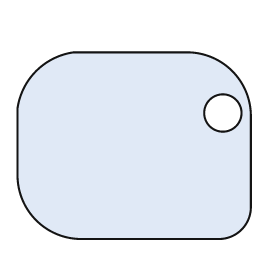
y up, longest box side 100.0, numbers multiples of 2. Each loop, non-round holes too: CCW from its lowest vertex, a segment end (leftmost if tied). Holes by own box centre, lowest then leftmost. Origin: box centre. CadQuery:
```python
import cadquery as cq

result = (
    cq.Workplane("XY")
    .moveTo(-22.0, -40.0)
    .lineTo(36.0, -40.0)
    .threePointArc((46.0, -36.0), (50.0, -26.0))
    .lineTo(50.0, 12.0)
    .threePointArc((42.0, 32.0), (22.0, 40.0))
    .lineTo(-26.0, 40.0)
    .threePointArc((-42.0, 32.0), (-50.0, 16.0))
    .lineTo(-50.0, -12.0)
    .threePointArc((-42.0, -32.0), (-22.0, -40.0))
    .close()
    .moveTo(38.0, 14.0)
    .circle(8.0)
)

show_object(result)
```